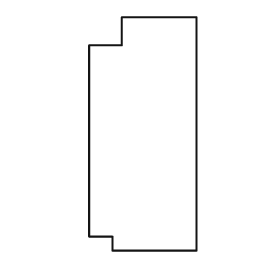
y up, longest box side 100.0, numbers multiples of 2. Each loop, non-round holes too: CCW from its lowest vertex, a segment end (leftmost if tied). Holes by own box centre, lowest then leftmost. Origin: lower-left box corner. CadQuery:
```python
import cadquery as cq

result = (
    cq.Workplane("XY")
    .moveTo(10.0, 0.0)
    .lineTo(46.0, 0.0)
    .lineTo(46.0, 100.0)
    .lineTo(14.0, 100.0)
    .lineTo(14.0, 88.0)
    .lineTo(0.0, 88.0)
    .lineTo(0.0, 6.0)
    .lineTo(10.0, 6.0)
    .close()
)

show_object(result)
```